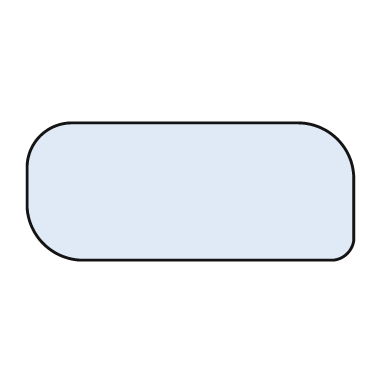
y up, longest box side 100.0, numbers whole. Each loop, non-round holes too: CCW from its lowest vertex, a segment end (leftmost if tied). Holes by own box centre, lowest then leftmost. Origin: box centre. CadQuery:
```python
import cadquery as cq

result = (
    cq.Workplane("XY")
    .moveTo(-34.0, -21.0)
    .lineTo(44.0, -21.0)
    .threePointArc((48.0, -19.0), (50.0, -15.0))
    .lineTo(50.0, 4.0)
    .threePointArc((45.0, 16.0), (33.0, 21.0))
    .lineTo(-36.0, 21.0)
    .threePointArc((-46.0, 17.0), (-50.0, 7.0))
    .lineTo(-50.0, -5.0)
    .threePointArc((-45.0, -16.0), (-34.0, -21.0))
    .close()
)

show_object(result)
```